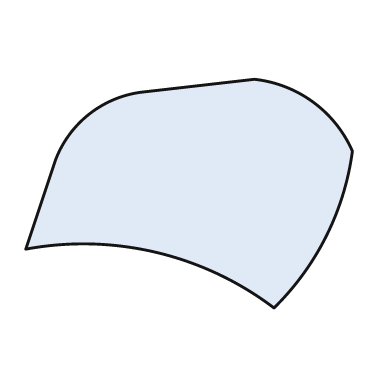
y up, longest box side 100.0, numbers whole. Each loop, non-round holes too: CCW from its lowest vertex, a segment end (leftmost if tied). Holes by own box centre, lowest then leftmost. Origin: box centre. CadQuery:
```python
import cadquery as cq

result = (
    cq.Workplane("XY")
    .moveTo(26.0, -35.0)
    .threePointArc((42.0, -13.0), (50.0, 13.0))
    .threePointArc((38.0, 28.0), (20.0, 35.0))
    .lineTo(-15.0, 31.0)
    .threePointArc((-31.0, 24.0), (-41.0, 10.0))
    .lineTo(-50.0, -17.0)
    .threePointArc((-10.0, -18.0), (26.0, -35.0))
    .close()
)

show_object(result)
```